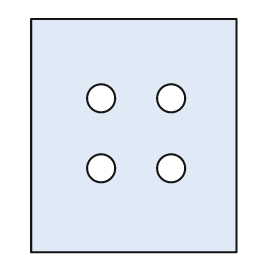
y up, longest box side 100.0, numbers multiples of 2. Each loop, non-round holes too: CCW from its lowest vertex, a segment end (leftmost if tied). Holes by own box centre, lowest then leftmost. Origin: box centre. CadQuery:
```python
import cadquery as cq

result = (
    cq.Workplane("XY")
    .moveTo(-44.0, -50.0)
    .lineTo(44.0, -50.0)
    .lineTo(44.0, 50.0)
    .lineTo(-44.0, 50.0)
    .close()
    .moveTo(-14.0, -14.0)
    .circle(6.0)
    .moveTo(16.0, -14.0)
    .circle(6.0)
    .moveTo(-14.0, 16.0)
    .circle(6.0)
    .moveTo(16.0, 16.0)
    .circle(6.0)
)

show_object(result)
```